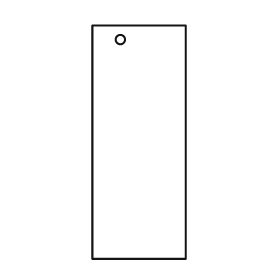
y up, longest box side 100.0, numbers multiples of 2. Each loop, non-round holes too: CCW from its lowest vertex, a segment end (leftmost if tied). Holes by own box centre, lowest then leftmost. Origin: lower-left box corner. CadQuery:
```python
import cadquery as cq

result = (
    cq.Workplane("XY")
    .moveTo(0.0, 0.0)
    .lineTo(40.0, 0.0)
    .lineTo(40.0, 100.0)
    .lineTo(0.0, 100.0)
    .close()
    .moveTo(12.0, 94.0)
    .circle(2.0)
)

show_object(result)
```